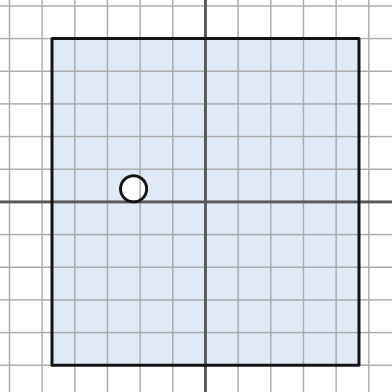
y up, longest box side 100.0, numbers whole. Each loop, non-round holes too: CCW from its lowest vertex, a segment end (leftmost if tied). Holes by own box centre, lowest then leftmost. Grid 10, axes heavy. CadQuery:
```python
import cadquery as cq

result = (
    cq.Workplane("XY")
    .moveTo(-47.0, -50.0)
    .lineTo(47.0, -50.0)
    .lineTo(47.0, 50.0)
    .lineTo(-47.0, 50.0)
    .close()
    .moveTo(-22.0, 4.0)
    .circle(4.0)
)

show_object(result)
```